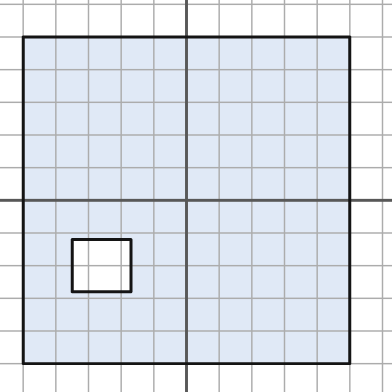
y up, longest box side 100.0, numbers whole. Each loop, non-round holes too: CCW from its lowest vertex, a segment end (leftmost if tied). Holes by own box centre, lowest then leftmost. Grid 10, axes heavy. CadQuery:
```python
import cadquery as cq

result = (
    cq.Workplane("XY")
    .moveTo(-50.0, -50.0)
    .lineTo(50.0, -50.0)
    .lineTo(50.0, 50.0)
    .lineTo(-50.0, 50.0)
    .close()
    .moveTo(-35.0, -28.0)
    .lineTo(-17.0, -28.0)
    .lineTo(-17.0, -12.0)
    .lineTo(-35.0, -12.0)
    .close()
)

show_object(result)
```